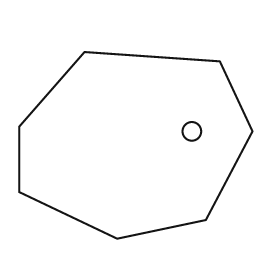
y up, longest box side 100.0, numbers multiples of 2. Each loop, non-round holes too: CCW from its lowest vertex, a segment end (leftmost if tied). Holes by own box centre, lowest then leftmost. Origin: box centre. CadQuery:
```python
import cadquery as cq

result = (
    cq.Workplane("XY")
    .moveTo(-8.0, -40.0)
    .lineTo(30.0, -32.0)
    .lineTo(50.0, 6.0)
    .lineTo(36.0, 36.0)
    .lineTo(-22.0, 40.0)
    .lineTo(-50.0, 8.0)
    .lineTo(-50.0, -20.0)
    .close()
    .moveTo(24.0, 6.0)
    .circle(4.0)
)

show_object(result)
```